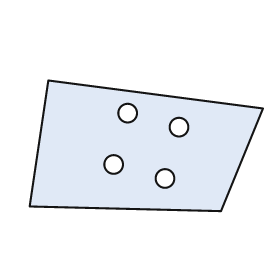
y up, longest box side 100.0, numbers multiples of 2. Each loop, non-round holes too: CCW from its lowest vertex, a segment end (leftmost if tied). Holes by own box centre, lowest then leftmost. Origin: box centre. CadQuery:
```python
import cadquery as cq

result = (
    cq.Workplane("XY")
    .moveTo(32.0, -28.0)
    .lineTo(50.0, 16.0)
    .lineTo(-42.0, 28.0)
    .lineTo(-50.0, -26.0)
    .close()
    .moveTo(8.0, -14.0)
    .circle(4.0)
    .moveTo(-14.0, -8.0)
    .circle(4.0)
    .moveTo(14.0, 8.0)
    .circle(4.0)
    .moveTo(-8.0, 14.0)
    .circle(4.0)
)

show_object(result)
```